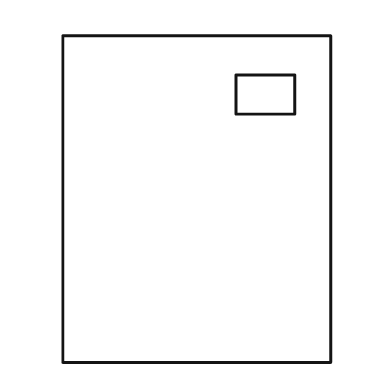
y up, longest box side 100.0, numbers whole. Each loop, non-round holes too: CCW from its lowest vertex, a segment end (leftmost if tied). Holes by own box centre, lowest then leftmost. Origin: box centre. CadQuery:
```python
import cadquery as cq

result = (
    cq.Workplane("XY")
    .moveTo(-41.0, -50.0)
    .lineTo(41.0, -50.0)
    .lineTo(41.0, 50.0)
    .lineTo(-41.0, 50.0)
    .close()
    .moveTo(12.0, 26.0)
    .lineTo(30.0, 26.0)
    .lineTo(30.0, 38.0)
    .lineTo(12.0, 38.0)
    .close()
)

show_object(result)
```